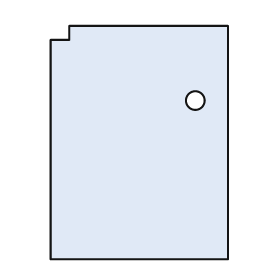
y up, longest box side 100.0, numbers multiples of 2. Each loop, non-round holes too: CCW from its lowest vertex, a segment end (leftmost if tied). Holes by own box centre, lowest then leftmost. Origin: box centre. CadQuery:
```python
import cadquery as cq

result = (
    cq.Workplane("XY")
    .moveTo(-38.0, -50.0)
    .lineTo(38.0, -50.0)
    .lineTo(38.0, 50.0)
    .lineTo(-30.0, 50.0)
    .lineTo(-30.0, 44.0)
    .lineTo(-38.0, 44.0)
    .close()
    .moveTo(24.0, 18.0)
    .circle(4.0)
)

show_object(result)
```